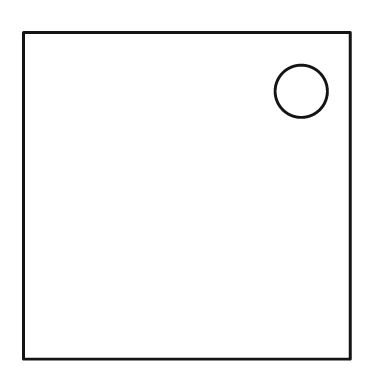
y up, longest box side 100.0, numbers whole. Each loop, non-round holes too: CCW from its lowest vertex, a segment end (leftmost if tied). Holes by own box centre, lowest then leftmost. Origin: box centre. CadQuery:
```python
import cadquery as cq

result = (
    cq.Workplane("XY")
    .moveTo(-50.0, -50.0)
    .lineTo(50.0, -50.0)
    .lineTo(50.0, 50.0)
    .lineTo(-50.0, 50.0)
    .close()
    .moveTo(35.0, 32.0)
    .circle(8.0)
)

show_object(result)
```